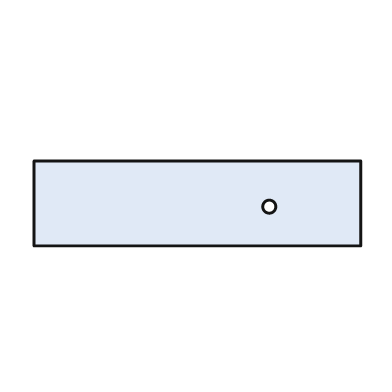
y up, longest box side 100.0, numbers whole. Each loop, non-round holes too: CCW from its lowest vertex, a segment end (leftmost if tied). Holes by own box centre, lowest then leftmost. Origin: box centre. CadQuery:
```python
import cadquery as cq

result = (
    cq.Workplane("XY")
    .moveTo(-50.0, -13.0)
    .lineTo(50.0, -13.0)
    .lineTo(50.0, 13.0)
    .lineTo(-50.0, 13.0)
    .close()
    .moveTo(22.0, -1.0)
    .circle(2.0)
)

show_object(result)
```